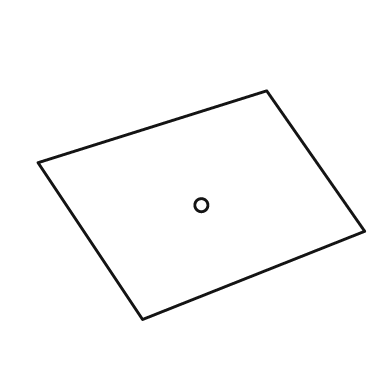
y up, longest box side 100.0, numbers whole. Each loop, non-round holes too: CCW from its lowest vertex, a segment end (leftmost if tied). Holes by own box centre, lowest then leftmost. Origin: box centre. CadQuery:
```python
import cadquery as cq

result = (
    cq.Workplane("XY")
    .moveTo(-18.0, -35.0)
    .lineTo(50.0, -8.0)
    .lineTo(20.0, 35.0)
    .lineTo(-50.0, 13.0)
    .close()
    .moveTo(0.0, 0.0)
    .circle(2.0)
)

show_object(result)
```